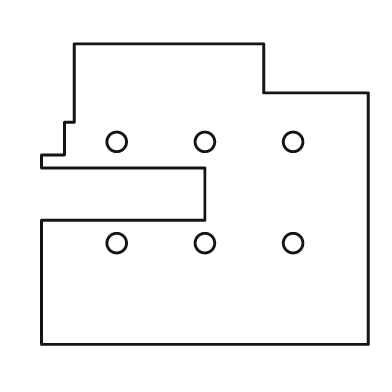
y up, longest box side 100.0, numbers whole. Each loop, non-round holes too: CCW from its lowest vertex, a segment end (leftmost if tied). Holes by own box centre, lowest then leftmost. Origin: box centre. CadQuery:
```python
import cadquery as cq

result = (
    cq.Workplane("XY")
    .moveTo(-50.0, -46.0)
    .lineTo(50.0, -46.0)
    .lineTo(50.0, 31.0)
    .lineTo(18.0, 31.0)
    .lineTo(18.0, 46.0)
    .lineTo(-40.0, 46.0)
    .lineTo(-40.0, 22.0)
    .lineTo(-43.0, 22.0)
    .lineTo(-43.0, 12.0)
    .lineTo(-50.0, 12.0)
    .lineTo(-50.0, 8.0)
    .lineTo(0.0, 8.0)
    .lineTo(0.0, -8.0)
    .lineTo(-50.0, -8.0)
    .close()
    .moveTo(-27.0, -15.0)
    .circle(3.0)
    .moveTo(0.0, -15.0)
    .circle(3.0)
    .moveTo(27.0, -15.0)
    .circle(3.0)
    .moveTo(-27.0, 16.0)
    .circle(3.0)
    .moveTo(0.0, 16.0)
    .circle(3.0)
    .moveTo(27.0, 16.0)
    .circle(3.0)
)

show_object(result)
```